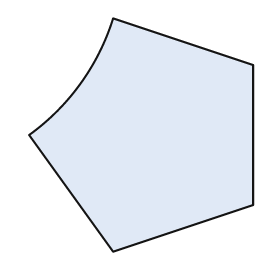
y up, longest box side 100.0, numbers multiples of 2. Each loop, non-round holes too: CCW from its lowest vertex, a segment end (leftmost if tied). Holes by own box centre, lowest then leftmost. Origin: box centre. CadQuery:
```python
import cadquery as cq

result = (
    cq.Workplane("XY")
    .moveTo(-12.0, -50.0)
    .lineTo(48.0, -30.0)
    .lineTo(48.0, 30.0)
    .lineTo(-12.0, 50.0)
    .threePointArc((-26.0, 22.0), (-48.0, 0.0))
    .close()
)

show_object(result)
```